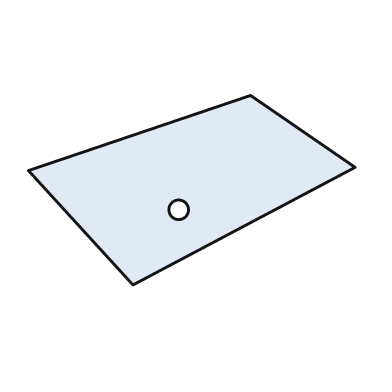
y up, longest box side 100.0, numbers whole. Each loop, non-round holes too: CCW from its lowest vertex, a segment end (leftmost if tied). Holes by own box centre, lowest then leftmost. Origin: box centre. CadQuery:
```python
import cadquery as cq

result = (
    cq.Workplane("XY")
    .moveTo(-18.0, -29.0)
    .lineTo(50.0, 7.0)
    .lineTo(18.0, 29.0)
    .lineTo(-50.0, 6.0)
    .close()
    .moveTo(-4.0, -6.0)
    .circle(3.0)
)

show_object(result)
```